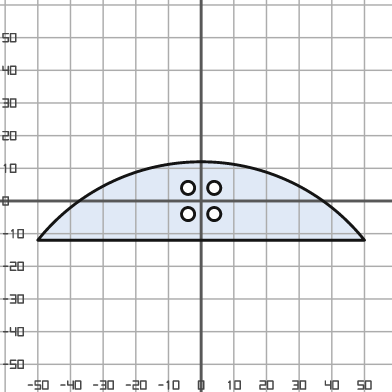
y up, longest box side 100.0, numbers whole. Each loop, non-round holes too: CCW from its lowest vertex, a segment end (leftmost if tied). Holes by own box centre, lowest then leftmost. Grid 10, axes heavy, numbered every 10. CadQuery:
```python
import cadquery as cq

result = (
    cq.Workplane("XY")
    .moveTo(-50.0, -12.0)
    .lineTo(50.0, -12.0)
    .threePointArc((0.0, 12.0), (-50.0, -12.0))
    .close()
    .moveTo(-4.0, -4.0)
    .circle(2.0)
    .moveTo(4.0, -4.0)
    .circle(2.0)
    .moveTo(-4.0, 4.0)
    .circle(2.0)
    .moveTo(4.0, 4.0)
    .circle(2.0)
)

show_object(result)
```